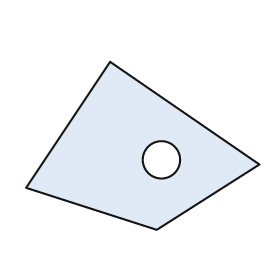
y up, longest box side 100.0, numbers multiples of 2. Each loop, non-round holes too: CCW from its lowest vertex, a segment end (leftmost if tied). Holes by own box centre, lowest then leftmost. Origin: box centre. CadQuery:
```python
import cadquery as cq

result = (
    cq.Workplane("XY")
    .moveTo(6.0, -36.0)
    .lineTo(50.0, -8.0)
    .lineTo(-14.0, 36.0)
    .lineTo(-50.0, -18.0)
    .close()
    .moveTo(8.0, -6.0)
    .circle(8.0)
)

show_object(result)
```